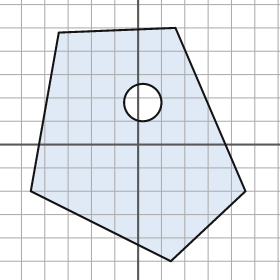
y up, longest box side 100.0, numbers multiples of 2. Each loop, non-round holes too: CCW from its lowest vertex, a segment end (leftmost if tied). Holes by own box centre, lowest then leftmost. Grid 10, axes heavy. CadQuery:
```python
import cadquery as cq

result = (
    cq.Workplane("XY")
    .moveTo(14.0, -50.0)
    .lineTo(46.0, -20.0)
    .lineTo(16.0, 50.0)
    .lineTo(-34.0, 48.0)
    .lineTo(-46.0, -20.0)
    .close()
    .moveTo(2.0, 18.0)
    .circle(8.0)
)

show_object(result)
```